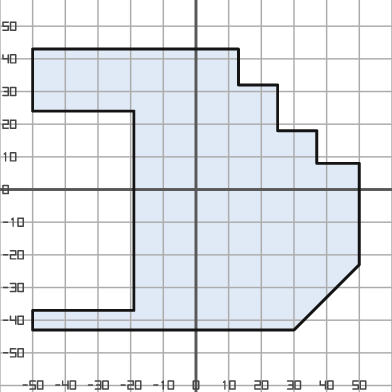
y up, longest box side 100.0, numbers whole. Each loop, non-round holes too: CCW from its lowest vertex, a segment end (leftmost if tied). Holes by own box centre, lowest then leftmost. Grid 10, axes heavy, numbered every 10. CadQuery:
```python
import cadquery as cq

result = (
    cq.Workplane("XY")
    .moveTo(-50.0, -43.0)
    .lineTo(30.0, -43.0)
    .lineTo(50.0, -23.0)
    .lineTo(50.0, 8.0)
    .lineTo(37.0, 8.0)
    .lineTo(37.0, 18.0)
    .lineTo(25.0, 18.0)
    .lineTo(25.0, 32.0)
    .lineTo(13.0, 32.0)
    .lineTo(13.0, 43.0)
    .lineTo(-50.0, 43.0)
    .lineTo(-50.0, 24.0)
    .lineTo(-19.0, 24.0)
    .lineTo(-19.0, -37.0)
    .lineTo(-50.0, -37.0)
    .close()
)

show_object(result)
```